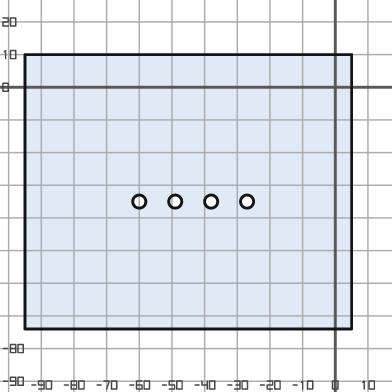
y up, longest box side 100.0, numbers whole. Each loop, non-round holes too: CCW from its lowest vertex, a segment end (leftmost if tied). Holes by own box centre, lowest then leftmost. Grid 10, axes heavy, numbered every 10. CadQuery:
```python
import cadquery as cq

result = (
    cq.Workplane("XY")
    .moveTo(-95.0, -74.0)
    .lineTo(5.0, -74.0)
    .lineTo(5.0, 10.0)
    .lineTo(-95.0, 10.0)
    .close()
    .moveTo(-60.0, -35.0)
    .circle(2.0)
    .moveTo(-49.0, -35.0)
    .circle(2.0)
    .moveTo(-38.0, -35.0)
    .circle(2.0)
    .moveTo(-27.0, -35.0)
    .circle(2.0)
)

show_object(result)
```